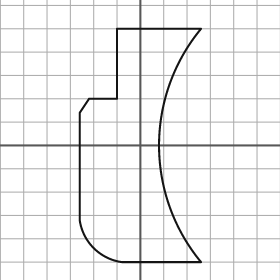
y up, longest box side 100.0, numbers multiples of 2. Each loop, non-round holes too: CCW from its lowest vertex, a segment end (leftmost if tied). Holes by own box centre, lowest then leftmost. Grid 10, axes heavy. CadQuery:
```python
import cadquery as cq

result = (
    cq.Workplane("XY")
    .moveTo(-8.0, -50.0)
    .lineTo(26.0, -50.0)
    .threePointArc((8.0, 0.0), (26.0, 50.0))
    .lineTo(-10.0, 50.0)
    .lineTo(-10.0, 20.0)
    .lineTo(-22.0, 20.0)
    .lineTo(-26.0, 14.0)
    .lineTo(-26.0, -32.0)
    .threePointArc((-20.0, -44.0), (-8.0, -50.0))
    .close()
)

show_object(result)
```